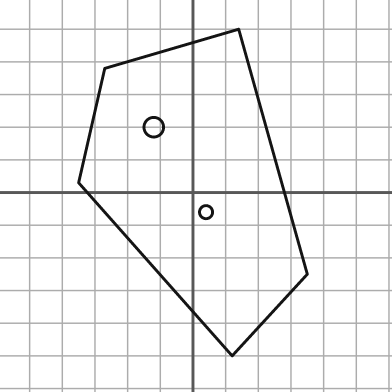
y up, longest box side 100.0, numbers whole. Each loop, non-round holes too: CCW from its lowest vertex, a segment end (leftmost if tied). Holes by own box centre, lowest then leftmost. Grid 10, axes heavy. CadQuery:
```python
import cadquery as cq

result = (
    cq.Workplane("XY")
    .moveTo(12.0, -50.0)
    .lineTo(35.0, -25.0)
    .lineTo(14.0, 50.0)
    .lineTo(-27.0, 38.0)
    .lineTo(-35.0, 3.0)
    .close()
    .moveTo(4.0, -6.0)
    .circle(2.0)
    .moveTo(-12.0, 20.0)
    .circle(3.0)
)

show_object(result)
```